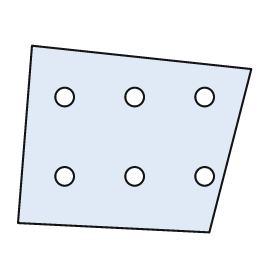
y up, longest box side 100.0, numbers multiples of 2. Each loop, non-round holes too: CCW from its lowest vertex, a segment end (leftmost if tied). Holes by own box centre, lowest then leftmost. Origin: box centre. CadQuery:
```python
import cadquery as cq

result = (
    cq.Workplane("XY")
    .moveTo(32.0, -40.0)
    .lineTo(50.0, 30.0)
    .lineTo(-44.0, 40.0)
    .lineTo(-50.0, -36.0)
    .close()
    .moveTo(-30.0, -16.0)
    .circle(4.0)
    .moveTo(0.0, -16.0)
    .circle(4.0)
    .moveTo(30.0, -16.0)
    .circle(4.0)
    .moveTo(-30.0, 18.0)
    .circle(4.0)
    .moveTo(0.0, 18.0)
    .circle(4.0)
    .moveTo(30.0, 18.0)
    .circle(4.0)
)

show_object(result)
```